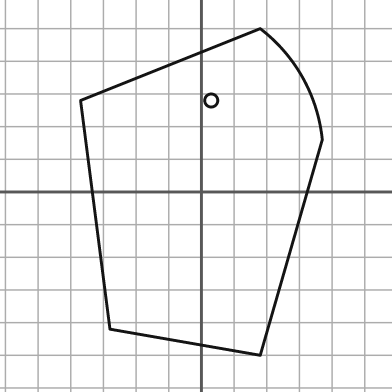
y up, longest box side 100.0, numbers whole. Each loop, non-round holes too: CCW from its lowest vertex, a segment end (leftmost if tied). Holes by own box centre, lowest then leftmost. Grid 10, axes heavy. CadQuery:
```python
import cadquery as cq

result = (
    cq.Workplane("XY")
    .moveTo(18.0, -50.0)
    .lineTo(37.0, 16.0)
    .threePointArc((31.0, 35.0), (18.0, 50.0))
    .lineTo(-37.0, 28.0)
    .lineTo(-28.0, -42.0)
    .close()
    .moveTo(3.0, 28.0)
    .circle(2.0)
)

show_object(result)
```